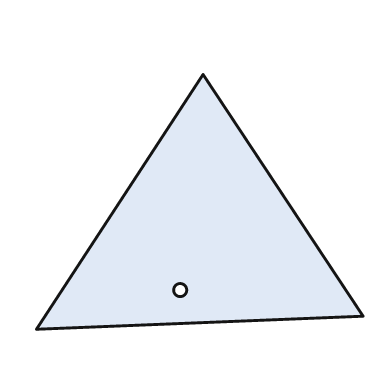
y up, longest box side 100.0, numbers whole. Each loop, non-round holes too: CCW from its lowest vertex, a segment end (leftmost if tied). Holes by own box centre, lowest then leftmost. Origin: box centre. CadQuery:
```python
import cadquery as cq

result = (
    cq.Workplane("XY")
    .moveTo(-50.0, -39.0)
    .lineTo(50.0, -35.0)
    .lineTo(1.0, 39.0)
    .close()
    .moveTo(-6.0, -27.0)
    .circle(2.0)
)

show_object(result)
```